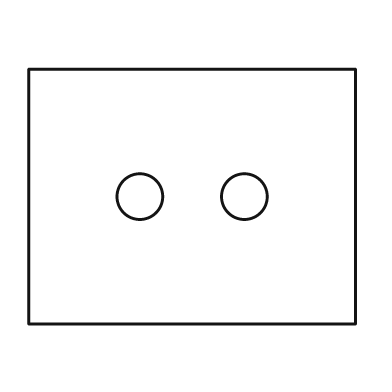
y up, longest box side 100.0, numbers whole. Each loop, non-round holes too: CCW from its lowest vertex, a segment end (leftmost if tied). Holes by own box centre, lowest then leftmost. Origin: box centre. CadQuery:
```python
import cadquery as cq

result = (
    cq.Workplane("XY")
    .moveTo(-50.0, -39.0)
    .lineTo(50.0, -39.0)
    .lineTo(50.0, 39.0)
    .lineTo(-50.0, 39.0)
    .close()
    .moveTo(-16.0, 0.0)
    .circle(7.0)
    .moveTo(16.0, 0.0)
    .circle(7.0)
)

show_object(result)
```